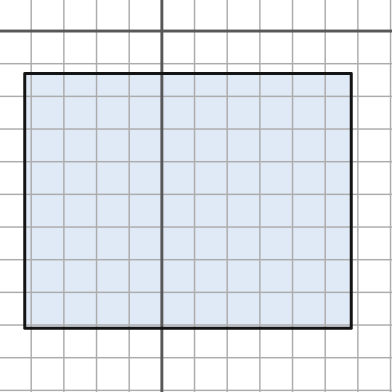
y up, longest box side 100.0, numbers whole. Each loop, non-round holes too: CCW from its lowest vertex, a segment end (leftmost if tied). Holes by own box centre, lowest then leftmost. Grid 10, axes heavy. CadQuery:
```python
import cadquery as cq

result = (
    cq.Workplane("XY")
    .moveTo(-42.0, -91.0)
    .lineTo(58.0, -91.0)
    .lineTo(58.0, -13.0)
    .lineTo(-42.0, -13.0)
    .close()
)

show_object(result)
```